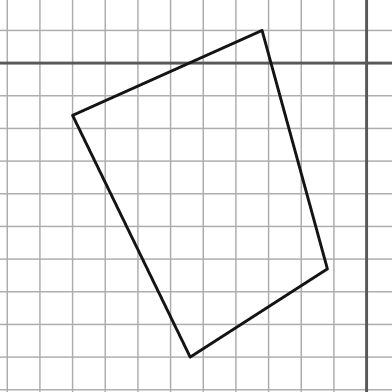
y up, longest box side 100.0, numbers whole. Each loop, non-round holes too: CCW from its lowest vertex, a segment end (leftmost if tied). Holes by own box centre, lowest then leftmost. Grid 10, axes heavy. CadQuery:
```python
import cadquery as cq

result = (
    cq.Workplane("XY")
    .moveTo(-54.0, -90.0)
    .lineTo(-12.0, -63.0)
    .lineTo(-32.0, 10.0)
    .lineTo(-90.0, -16.0)
    .close()
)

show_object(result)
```